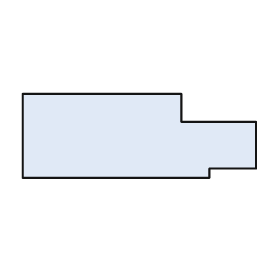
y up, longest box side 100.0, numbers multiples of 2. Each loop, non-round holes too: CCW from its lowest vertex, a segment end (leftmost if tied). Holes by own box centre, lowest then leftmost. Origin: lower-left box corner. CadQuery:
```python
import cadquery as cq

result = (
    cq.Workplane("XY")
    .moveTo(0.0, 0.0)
    .lineTo(80.0, 0.0)
    .lineTo(80.0, 4.0)
    .lineTo(100.0, 4.0)
    .lineTo(100.0, 24.0)
    .lineTo(68.0, 24.0)
    .lineTo(68.0, 36.0)
    .lineTo(0.0, 36.0)
    .close()
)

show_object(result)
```